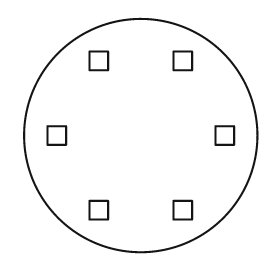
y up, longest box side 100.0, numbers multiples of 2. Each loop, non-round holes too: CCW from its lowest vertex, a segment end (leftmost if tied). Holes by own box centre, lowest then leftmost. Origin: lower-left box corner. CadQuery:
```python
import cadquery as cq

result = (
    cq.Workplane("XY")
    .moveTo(50.0, 50.0)
    .circle(50.0)
    .moveTo(28.0, 14.0)
    .lineTo(36.0, 14.0)
    .lineTo(36.0, 22.0)
    .lineTo(28.0, 22.0)
    .close()
    .moveTo(64.0, 14.0)
    .lineTo(72.0, 14.0)
    .lineTo(72.0, 22.0)
    .lineTo(64.0, 22.0)
    .close()
    .moveTo(10.0, 46.0)
    .lineTo(18.0, 46.0)
    .lineTo(18.0, 54.0)
    .lineTo(10.0, 54.0)
    .close()
    .moveTo(82.0, 46.0)
    .lineTo(90.0, 46.0)
    .lineTo(90.0, 54.0)
    .lineTo(82.0, 54.0)
    .close()
    .moveTo(28.0, 78.0)
    .lineTo(36.0, 78.0)
    .lineTo(36.0, 86.0)
    .lineTo(28.0, 86.0)
    .close()
    .moveTo(64.0, 78.0)
    .lineTo(72.0, 78.0)
    .lineTo(72.0, 86.0)
    .lineTo(64.0, 86.0)
    .close()
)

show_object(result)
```